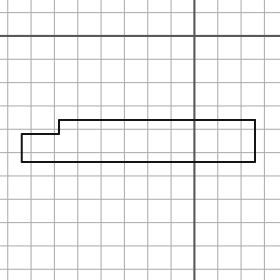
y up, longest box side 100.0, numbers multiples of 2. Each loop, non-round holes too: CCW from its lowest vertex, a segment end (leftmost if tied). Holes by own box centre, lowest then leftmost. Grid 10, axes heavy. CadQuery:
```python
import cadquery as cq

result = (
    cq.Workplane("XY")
    .moveTo(-74.0, -54.0)
    .lineTo(26.0, -54.0)
    .lineTo(26.0, -36.0)
    .lineTo(-58.0, -36.0)
    .lineTo(-58.0, -42.0)
    .lineTo(-74.0, -42.0)
    .close()
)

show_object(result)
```